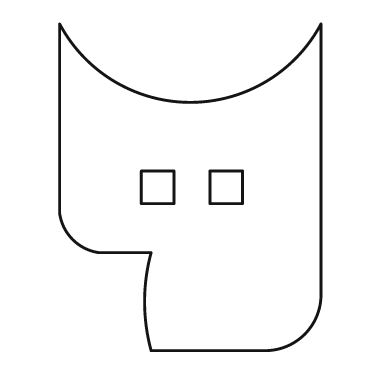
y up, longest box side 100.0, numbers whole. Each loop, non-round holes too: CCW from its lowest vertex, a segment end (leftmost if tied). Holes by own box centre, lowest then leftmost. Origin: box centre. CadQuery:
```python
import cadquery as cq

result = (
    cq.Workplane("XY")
    .moveTo(-12.0, -50.0)
    .lineTo(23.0, -50.0)
    .threePointArc((35.0, -45.0), (40.0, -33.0))
    .lineTo(40.0, 50.0)
    .threePointArc((0.0, 26.0), (-40.0, 50.0))
    .lineTo(-40.0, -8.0)
    .threePointArc((-36.0, -16.0), (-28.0, -20.0))
    .lineTo(-12.0, -20.0)
    .threePointArc((-14.0, -35.0), (-12.0, -50.0))
    .close()
    .moveTo(-15.0, -5.0)
    .lineTo(-5.0, -5.0)
    .lineTo(-5.0, 5.0)
    .lineTo(-15.0, 5.0)
    .close()
    .moveTo(6.0, -5.0)
    .lineTo(16.0, -5.0)
    .lineTo(16.0, 5.0)
    .lineTo(6.0, 5.0)
    .close()
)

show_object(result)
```